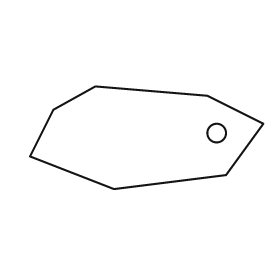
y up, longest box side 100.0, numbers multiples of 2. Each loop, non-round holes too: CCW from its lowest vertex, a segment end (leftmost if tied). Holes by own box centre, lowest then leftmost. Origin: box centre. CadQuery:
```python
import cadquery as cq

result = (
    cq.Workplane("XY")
    .moveTo(-14.0, -22.0)
    .lineTo(34.0, -16.0)
    .lineTo(50.0, 6.0)
    .lineTo(26.0, 18.0)
    .lineTo(-22.0, 22.0)
    .lineTo(-40.0, 12.0)
    .lineTo(-50.0, -8.0)
    .close()
    .moveTo(30.0, 2.0)
    .circle(4.0)
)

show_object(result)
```